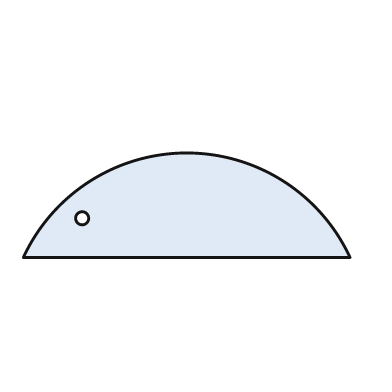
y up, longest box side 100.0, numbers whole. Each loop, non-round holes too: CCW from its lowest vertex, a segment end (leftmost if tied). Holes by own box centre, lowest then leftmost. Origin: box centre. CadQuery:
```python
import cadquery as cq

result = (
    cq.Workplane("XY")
    .moveTo(-50.0, -16.0)
    .lineTo(50.0, -16.0)
    .threePointArc((0.0, 16.0), (-50.0, -16.0))
    .close()
    .moveTo(-32.0, -4.0)
    .circle(2.0)
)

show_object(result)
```